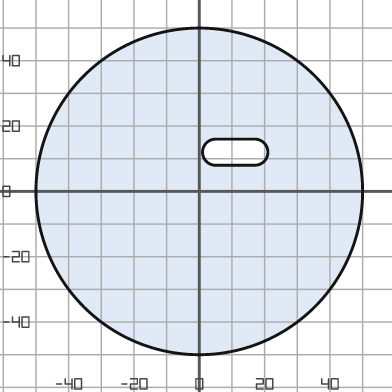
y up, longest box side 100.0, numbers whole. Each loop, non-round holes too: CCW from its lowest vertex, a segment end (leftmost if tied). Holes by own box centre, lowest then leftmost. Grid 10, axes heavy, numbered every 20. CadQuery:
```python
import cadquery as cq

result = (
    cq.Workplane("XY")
    .moveTo(0.0, 0.0)
    .circle(50.0)
    .moveTo(5.0, 8.0)
    .lineTo(17.0, 8.0)
    .threePointArc((21.0, 12.0), (17.0, 16.0))
    .lineTo(5.0, 16.0)
    .threePointArc((1.0, 12.0), (5.0, 8.0))
    .close()
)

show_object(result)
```